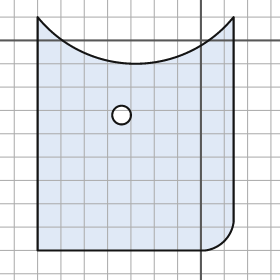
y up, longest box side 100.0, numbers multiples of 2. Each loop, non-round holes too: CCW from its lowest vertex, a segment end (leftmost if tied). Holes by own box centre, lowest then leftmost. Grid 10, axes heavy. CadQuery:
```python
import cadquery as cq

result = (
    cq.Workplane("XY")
    .moveTo(-70.0, -90.0)
    .lineTo(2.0, -90.0)
    .threePointArc((10.0, -86.0), (14.0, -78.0))
    .lineTo(14.0, 10.0)
    .threePointArc((-28.0, -10.0), (-70.0, 10.0))
    .close()
    .moveTo(-34.0, -32.0)
    .circle(4.0)
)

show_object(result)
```